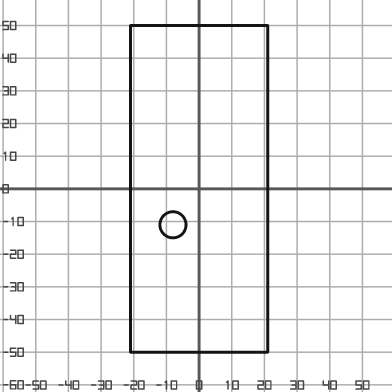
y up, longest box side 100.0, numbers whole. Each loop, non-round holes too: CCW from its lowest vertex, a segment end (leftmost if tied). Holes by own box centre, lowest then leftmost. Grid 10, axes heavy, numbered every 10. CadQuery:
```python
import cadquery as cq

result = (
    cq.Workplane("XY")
    .moveTo(-21.0, -50.0)
    .lineTo(21.0, -50.0)
    .lineTo(21.0, 50.0)
    .lineTo(-21.0, 50.0)
    .close()
    .moveTo(-8.0, -11.0)
    .circle(4.0)
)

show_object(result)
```